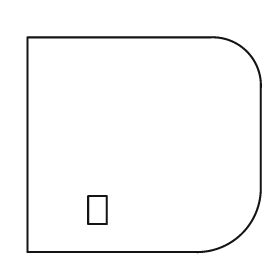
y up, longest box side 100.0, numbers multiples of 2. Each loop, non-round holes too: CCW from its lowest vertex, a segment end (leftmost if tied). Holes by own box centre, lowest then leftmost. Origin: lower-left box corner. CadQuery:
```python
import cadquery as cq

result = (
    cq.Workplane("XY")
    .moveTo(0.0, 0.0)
    .lineTo(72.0, 0.0)
    .threePointArc((92.0, 8.0), (100.0, 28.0))
    .lineTo(100.0, 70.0)
    .threePointArc((94.0, 86.0), (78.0, 92.0))
    .lineTo(0.0, 92.0)
    .close()
    .moveTo(26.0, 12.0)
    .lineTo(34.0, 12.0)
    .lineTo(34.0, 24.0)
    .lineTo(26.0, 24.0)
    .close()
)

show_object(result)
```